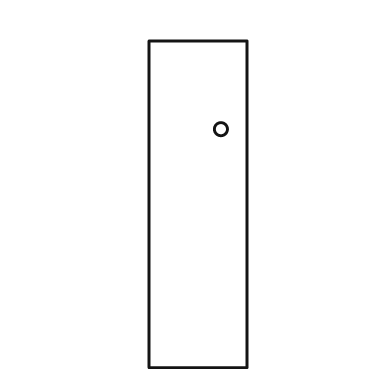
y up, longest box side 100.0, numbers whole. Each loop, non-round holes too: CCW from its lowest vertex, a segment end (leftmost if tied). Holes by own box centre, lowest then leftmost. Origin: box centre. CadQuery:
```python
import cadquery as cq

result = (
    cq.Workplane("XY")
    .moveTo(-15.0, -50.0)
    .lineTo(15.0, -50.0)
    .lineTo(15.0, 50.0)
    .lineTo(-15.0, 50.0)
    .close()
    .moveTo(7.0, 23.0)
    .circle(2.0)
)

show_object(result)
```